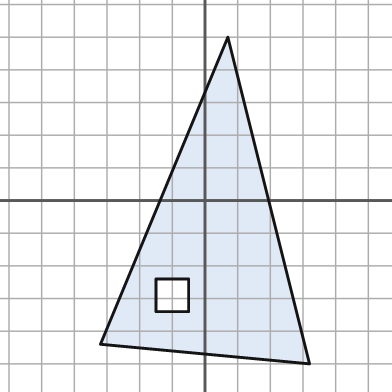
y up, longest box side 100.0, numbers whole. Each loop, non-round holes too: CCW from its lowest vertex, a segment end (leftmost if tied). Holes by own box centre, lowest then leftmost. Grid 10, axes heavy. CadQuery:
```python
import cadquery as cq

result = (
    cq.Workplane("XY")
    .moveTo(32.0, -50.0)
    .lineTo(7.0, 50.0)
    .lineTo(-32.0, -44.0)
    .close()
    .moveTo(-15.0, -34.0)
    .lineTo(-5.0, -34.0)
    .lineTo(-5.0, -24.0)
    .lineTo(-15.0, -24.0)
    .close()
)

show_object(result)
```